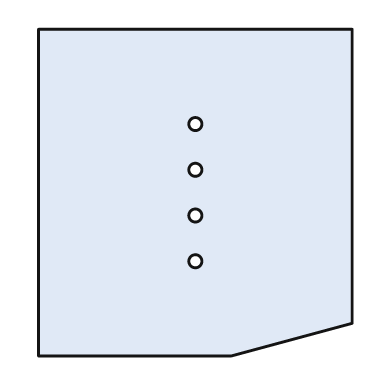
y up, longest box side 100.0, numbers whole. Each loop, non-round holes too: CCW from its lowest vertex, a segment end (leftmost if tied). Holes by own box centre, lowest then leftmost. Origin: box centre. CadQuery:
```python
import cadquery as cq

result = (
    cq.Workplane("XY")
    .moveTo(-48.0, -50.0)
    .lineTo(11.0, -50.0)
    .lineTo(48.0, -40.0)
    .lineTo(48.0, 50.0)
    .lineTo(-48.0, 50.0)
    .close()
    .moveTo(0.0, -21.0)
    .circle(2.0)
    .moveTo(0.0, -7.0)
    .circle(2.0)
    .moveTo(0.0, 7.0)
    .circle(2.0)
    .moveTo(0.0, 21.0)
    .circle(2.0)
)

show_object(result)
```